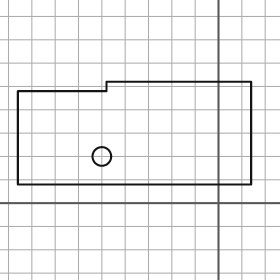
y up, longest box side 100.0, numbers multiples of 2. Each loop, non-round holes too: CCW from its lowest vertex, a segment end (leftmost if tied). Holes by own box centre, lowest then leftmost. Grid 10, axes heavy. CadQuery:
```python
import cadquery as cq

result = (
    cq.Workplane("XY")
    .moveTo(-86.0, 8.0)
    .lineTo(14.0, 8.0)
    .lineTo(14.0, 52.0)
    .lineTo(-48.0, 52.0)
    .lineTo(-48.0, 48.0)
    .lineTo(-86.0, 48.0)
    .close()
    .moveTo(-50.0, 20.0)
    .circle(4.0)
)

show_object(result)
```